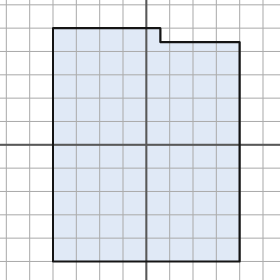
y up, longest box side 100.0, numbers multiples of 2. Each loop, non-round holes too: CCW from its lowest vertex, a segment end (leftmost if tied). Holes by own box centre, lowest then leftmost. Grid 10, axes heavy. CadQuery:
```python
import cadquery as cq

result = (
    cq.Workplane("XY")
    .moveTo(-40.0, -50.0)
    .lineTo(40.0, -50.0)
    .lineTo(40.0, 44.0)
    .lineTo(6.0, 44.0)
    .lineTo(6.0, 50.0)
    .lineTo(-40.0, 50.0)
    .close()
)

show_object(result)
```